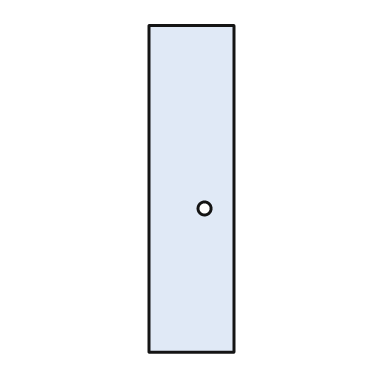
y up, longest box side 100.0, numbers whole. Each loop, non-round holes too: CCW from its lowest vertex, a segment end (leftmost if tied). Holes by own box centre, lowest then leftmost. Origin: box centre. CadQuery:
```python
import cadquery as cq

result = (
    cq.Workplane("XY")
    .moveTo(-13.0, -50.0)
    .lineTo(13.0, -50.0)
    .lineTo(13.0, 50.0)
    .lineTo(-13.0, 50.0)
    .close()
    .moveTo(4.0, -6.0)
    .circle(2.0)
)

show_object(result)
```